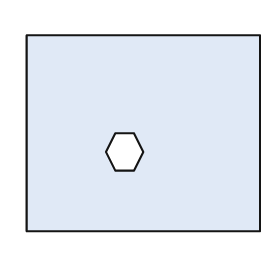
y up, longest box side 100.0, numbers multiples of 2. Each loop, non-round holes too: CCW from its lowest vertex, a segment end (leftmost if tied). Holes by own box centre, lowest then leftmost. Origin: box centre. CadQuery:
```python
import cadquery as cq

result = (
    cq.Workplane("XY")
    .moveTo(-50.0, -42.0)
    .lineTo(50.0, -42.0)
    .lineTo(50.0, 42.0)
    .lineTo(-50.0, 42.0)
    .close()
    .moveTo(-12.0, -16.0)
    .lineTo(-4.0, -16.0)
    .lineTo(0.0, -8.0)
    .lineTo(-4.0, 0.0)
    .lineTo(-12.0, 0.0)
    .lineTo(-16.0, -8.0)
    .close()
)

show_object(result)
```